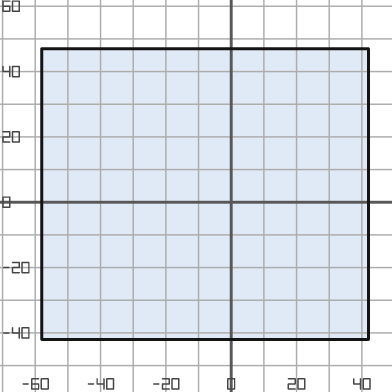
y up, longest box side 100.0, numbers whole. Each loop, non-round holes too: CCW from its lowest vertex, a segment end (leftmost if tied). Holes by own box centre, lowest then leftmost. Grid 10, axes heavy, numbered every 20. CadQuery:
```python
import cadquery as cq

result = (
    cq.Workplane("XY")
    .moveTo(-58.0, -42.0)
    .lineTo(42.0, -42.0)
    .lineTo(42.0, 47.0)
    .lineTo(-58.0, 47.0)
    .close()
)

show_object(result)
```